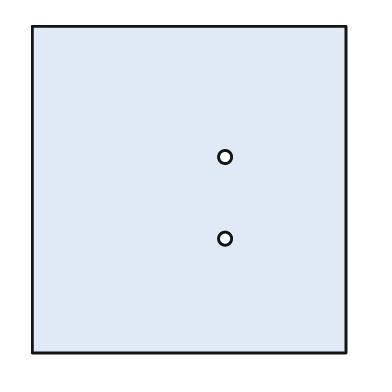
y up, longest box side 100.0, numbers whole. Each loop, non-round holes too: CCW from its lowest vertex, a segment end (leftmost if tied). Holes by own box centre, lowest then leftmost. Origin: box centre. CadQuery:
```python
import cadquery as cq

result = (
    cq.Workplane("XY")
    .moveTo(-48.0, -50.0)
    .lineTo(48.0, -50.0)
    .lineTo(48.0, 50.0)
    .lineTo(-48.0, 50.0)
    .close()
    .moveTo(11.0, -15.0)
    .circle(2.0)
    .moveTo(11.0, 10.0)
    .circle(2.0)
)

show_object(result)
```